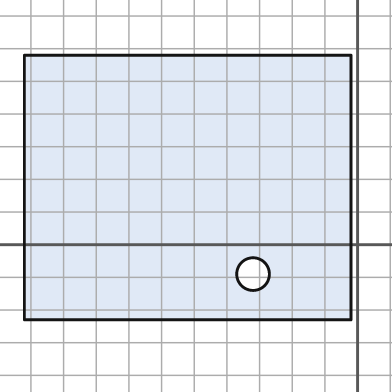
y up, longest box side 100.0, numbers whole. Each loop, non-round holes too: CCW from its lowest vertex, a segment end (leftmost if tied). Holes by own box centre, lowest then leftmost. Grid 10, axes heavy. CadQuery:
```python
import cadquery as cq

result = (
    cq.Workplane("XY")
    .moveTo(-102.0, -23.0)
    .lineTo(-2.0, -23.0)
    .lineTo(-2.0, 58.0)
    .lineTo(-102.0, 58.0)
    .close()
    .moveTo(-32.0, -9.0)
    .circle(5.0)
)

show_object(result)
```